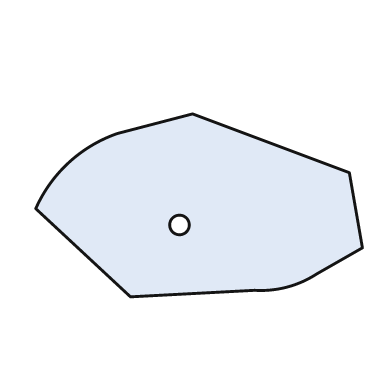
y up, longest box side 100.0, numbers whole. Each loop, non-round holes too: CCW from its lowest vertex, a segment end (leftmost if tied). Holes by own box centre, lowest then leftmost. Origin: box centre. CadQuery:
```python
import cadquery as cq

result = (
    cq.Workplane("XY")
    .moveTo(-21.0, -28.0)
    .lineTo(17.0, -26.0)
    .threePointArc((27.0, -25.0), (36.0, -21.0))
    .lineTo(50.0, -13.0)
    .lineTo(46.0, 10.0)
    .lineTo(-2.0, 28.0)
    .lineTo(-25.0, 22.0)
    .threePointArc((-40.0, 13.0), (-50.0, -1.0))
    .close()
    .moveTo(-6.0, -6.0)
    .circle(3.0)
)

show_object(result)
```